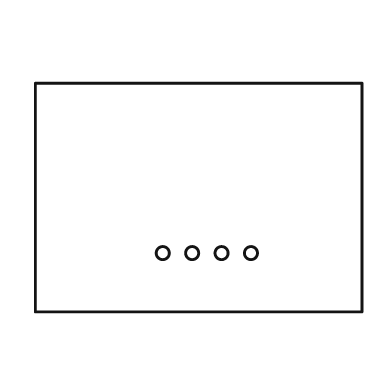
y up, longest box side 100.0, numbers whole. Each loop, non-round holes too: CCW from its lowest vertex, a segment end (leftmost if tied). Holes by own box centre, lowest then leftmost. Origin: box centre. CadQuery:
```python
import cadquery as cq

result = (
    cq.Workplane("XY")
    .moveTo(-50.0, -35.0)
    .lineTo(50.0, -35.0)
    .lineTo(50.0, 35.0)
    .lineTo(-50.0, 35.0)
    .close()
    .moveTo(-11.0, -17.0)
    .circle(2.0)
    .moveTo(-2.0, -17.0)
    .circle(2.0)
    .moveTo(7.0, -17.0)
    .circle(2.0)
    .moveTo(16.0, -17.0)
    .circle(2.0)
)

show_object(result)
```